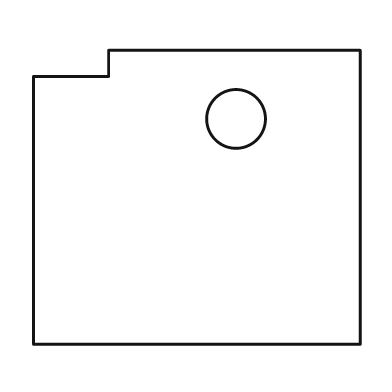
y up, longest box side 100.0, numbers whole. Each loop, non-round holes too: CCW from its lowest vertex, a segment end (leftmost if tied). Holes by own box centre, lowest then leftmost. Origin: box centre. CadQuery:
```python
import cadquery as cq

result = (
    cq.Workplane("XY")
    .moveTo(-50.0, -45.0)
    .lineTo(50.0, -45.0)
    .lineTo(50.0, 45.0)
    .lineTo(-27.0, 45.0)
    .lineTo(-27.0, 37.0)
    .lineTo(-50.0, 37.0)
    .close()
    .moveTo(12.0, 24.0)
    .circle(9.0)
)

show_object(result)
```